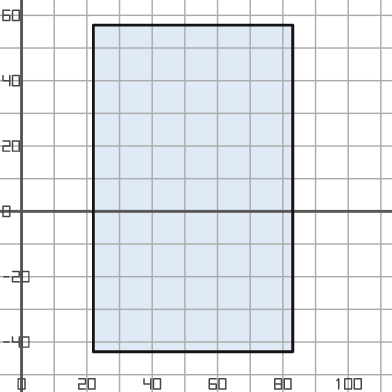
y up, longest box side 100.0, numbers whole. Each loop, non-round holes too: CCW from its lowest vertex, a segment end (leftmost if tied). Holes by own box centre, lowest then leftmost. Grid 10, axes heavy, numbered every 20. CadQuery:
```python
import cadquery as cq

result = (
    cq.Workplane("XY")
    .moveTo(22.0, -43.0)
    .lineTo(83.0, -43.0)
    .lineTo(83.0, 57.0)
    .lineTo(22.0, 57.0)
    .close()
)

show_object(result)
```